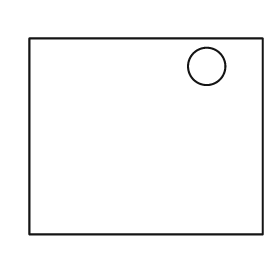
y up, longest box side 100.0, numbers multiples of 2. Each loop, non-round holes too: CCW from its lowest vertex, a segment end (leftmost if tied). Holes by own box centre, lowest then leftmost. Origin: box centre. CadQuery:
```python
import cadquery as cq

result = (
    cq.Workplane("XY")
    .moveTo(-50.0, -42.0)
    .lineTo(50.0, -42.0)
    .lineTo(50.0, 42.0)
    .lineTo(-50.0, 42.0)
    .close()
    .moveTo(26.0, 30.0)
    .circle(8.0)
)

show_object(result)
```